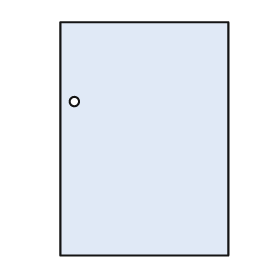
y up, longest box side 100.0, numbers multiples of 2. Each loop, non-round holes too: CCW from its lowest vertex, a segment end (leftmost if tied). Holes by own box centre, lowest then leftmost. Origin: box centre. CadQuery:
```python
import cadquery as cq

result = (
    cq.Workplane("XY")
    .moveTo(-36.0, -50.0)
    .lineTo(36.0, -50.0)
    .lineTo(36.0, 50.0)
    .lineTo(-36.0, 50.0)
    .close()
    .moveTo(-30.0, 16.0)
    .circle(2.0)
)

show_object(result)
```